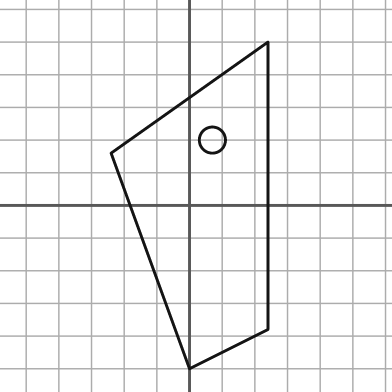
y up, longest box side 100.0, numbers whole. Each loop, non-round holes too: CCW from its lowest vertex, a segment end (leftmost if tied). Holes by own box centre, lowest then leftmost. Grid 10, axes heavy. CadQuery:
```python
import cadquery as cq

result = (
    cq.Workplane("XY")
    .moveTo(0.0, -50.0)
    .lineTo(24.0, -38.0)
    .lineTo(24.0, 50.0)
    .lineTo(-24.0, 16.0)
    .close()
    .moveTo(7.0, 20.0)
    .circle(4.0)
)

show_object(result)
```